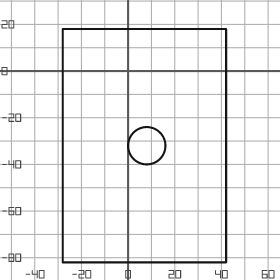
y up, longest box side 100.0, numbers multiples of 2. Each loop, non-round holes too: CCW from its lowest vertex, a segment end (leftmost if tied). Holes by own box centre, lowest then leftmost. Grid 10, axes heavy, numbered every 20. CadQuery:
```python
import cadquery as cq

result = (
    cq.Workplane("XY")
    .moveTo(-28.0, -82.0)
    .lineTo(42.0, -82.0)
    .lineTo(42.0, 18.0)
    .lineTo(-28.0, 18.0)
    .close()
    .moveTo(8.0, -32.0)
    .circle(8.0)
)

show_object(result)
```